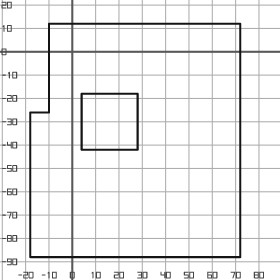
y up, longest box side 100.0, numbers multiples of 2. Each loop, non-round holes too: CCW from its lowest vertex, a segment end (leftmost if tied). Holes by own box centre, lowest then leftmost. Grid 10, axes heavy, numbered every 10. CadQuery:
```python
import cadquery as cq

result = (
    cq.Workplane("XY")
    .moveTo(-18.0, -88.0)
    .lineTo(72.0, -88.0)
    .lineTo(72.0, 12.0)
    .lineTo(-10.0, 12.0)
    .lineTo(-10.0, -26.0)
    .lineTo(-18.0, -26.0)
    .close()
    .moveTo(4.0, -42.0)
    .lineTo(28.0, -42.0)
    .lineTo(28.0, -18.0)
    .lineTo(4.0, -18.0)
    .close()
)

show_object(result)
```